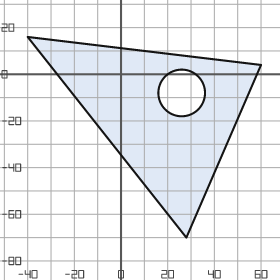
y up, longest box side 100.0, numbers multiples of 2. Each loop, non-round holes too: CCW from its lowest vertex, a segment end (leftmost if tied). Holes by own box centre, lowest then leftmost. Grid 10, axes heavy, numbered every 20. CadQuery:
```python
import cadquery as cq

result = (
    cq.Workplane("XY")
    .moveTo(28.0, -70.0)
    .lineTo(60.0, 4.0)
    .lineTo(-40.0, 16.0)
    .close()
    .moveTo(26.0, -8.0)
    .circle(10.0)
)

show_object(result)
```